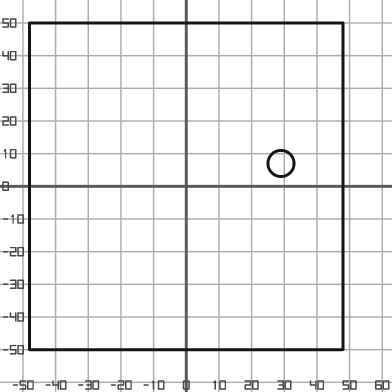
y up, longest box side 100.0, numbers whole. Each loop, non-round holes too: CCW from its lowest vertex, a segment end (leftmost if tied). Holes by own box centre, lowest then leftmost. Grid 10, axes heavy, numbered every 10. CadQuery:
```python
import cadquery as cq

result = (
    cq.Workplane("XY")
    .moveTo(-48.0, -50.0)
    .lineTo(48.0, -50.0)
    .lineTo(48.0, 50.0)
    .lineTo(-48.0, 50.0)
    .close()
    .moveTo(29.0, 7.0)
    .circle(4.0)
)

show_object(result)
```